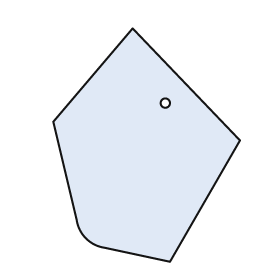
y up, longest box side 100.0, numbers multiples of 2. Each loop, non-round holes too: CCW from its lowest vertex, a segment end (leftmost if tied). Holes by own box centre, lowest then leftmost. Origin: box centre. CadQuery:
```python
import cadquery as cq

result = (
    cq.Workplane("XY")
    .moveTo(10.0, -50.0)
    .lineTo(40.0, 2.0)
    .lineTo(-6.0, 50.0)
    .lineTo(-40.0, 10.0)
    .lineTo(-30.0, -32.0)
    .threePointArc((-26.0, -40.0), (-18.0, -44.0))
    .close()
    .moveTo(8.0, 18.0)
    .circle(2.0)
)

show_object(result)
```